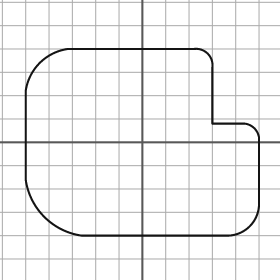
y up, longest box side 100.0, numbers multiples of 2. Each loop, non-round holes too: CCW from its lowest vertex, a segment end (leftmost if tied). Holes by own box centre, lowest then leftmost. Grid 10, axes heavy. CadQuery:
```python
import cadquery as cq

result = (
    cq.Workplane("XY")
    .moveTo(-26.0, -40.0)
    .lineTo(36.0, -40.0)
    .threePointArc((46.0, -36.0), (50.0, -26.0))
    .lineTo(50.0, 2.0)
    .threePointArc((48.0, 6.0), (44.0, 8.0))
    .lineTo(30.0, 8.0)
    .lineTo(30.0, 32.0)
    .threePointArc((28.0, 38.0), (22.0, 40.0))
    .lineTo(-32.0, 40.0)
    .threePointArc((-44.0, 34.0), (-50.0, 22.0))
    .lineTo(-50.0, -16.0)
    .threePointArc((-42.0, -32.0), (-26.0, -40.0))
    .close()
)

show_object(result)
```